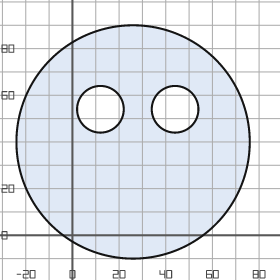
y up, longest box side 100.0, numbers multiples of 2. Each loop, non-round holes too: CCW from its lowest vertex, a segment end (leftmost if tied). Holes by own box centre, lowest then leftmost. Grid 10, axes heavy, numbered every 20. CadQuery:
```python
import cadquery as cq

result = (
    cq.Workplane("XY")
    .moveTo(26.0, 40.0)
    .circle(50.0)
    .moveTo(12.0, 54.0)
    .circle(10.0)
    .moveTo(44.0, 54.0)
    .circle(10.0)
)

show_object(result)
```